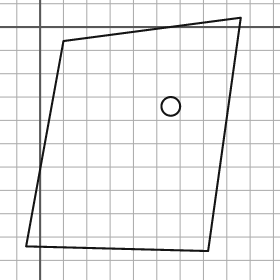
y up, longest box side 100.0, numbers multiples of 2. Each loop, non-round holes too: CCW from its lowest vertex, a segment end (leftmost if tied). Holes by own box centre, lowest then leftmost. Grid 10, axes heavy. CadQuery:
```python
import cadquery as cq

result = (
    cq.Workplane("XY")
    .moveTo(72.0, -96.0)
    .lineTo(86.0, 4.0)
    .lineTo(10.0, -6.0)
    .lineTo(-6.0, -94.0)
    .close()
    .moveTo(56.0, -34.0)
    .circle(4.0)
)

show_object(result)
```